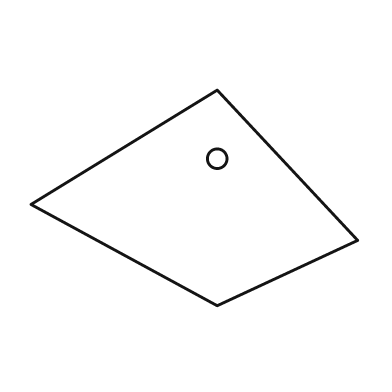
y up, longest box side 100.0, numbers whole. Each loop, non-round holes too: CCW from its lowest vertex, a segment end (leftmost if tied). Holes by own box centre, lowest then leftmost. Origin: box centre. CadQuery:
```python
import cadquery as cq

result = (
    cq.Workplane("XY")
    .moveTo(7.0, -33.0)
    .lineTo(50.0, -13.0)
    .lineTo(7.0, 33.0)
    .lineTo(-50.0, -2.0)
    .close()
    .moveTo(7.0, 12.0)
    .circle(3.0)
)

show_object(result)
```